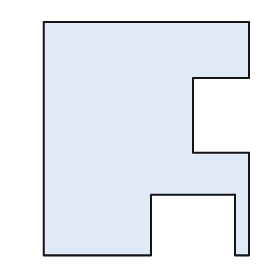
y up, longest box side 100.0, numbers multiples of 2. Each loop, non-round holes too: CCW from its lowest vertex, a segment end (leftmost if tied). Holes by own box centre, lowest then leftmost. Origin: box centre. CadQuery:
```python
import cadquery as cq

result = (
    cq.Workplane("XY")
    .moveTo(-44.0, -50.0)
    .lineTo(2.0, -50.0)
    .lineTo(2.0, -24.0)
    .lineTo(38.0, -24.0)
    .lineTo(38.0, -50.0)
    .lineTo(44.0, -50.0)
    .lineTo(44.0, -6.0)
    .lineTo(20.0, -6.0)
    .lineTo(20.0, 26.0)
    .lineTo(44.0, 26.0)
    .lineTo(44.0, 50.0)
    .lineTo(-44.0, 50.0)
    .close()
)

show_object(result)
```